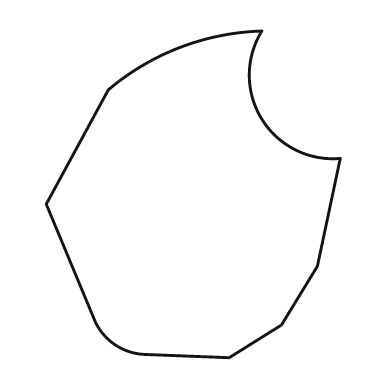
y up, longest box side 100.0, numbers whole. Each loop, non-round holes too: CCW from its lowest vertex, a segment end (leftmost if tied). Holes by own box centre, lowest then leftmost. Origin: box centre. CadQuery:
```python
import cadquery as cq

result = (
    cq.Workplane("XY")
    .moveTo(11.0, -50.0)
    .lineTo(27.0, -40.0)
    .lineTo(38.0, -22.0)
    .lineTo(45.0, 11.0)
    .threePointArc((21.0, 23.0), (21.0, 50.0))
    .threePointArc((-4.0, 45.0), (-26.0, 32.0))
    .lineTo(-45.0, -3.0)
    .lineTo(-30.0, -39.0)
    .threePointArc((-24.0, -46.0), (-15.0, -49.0))
    .close()
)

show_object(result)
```